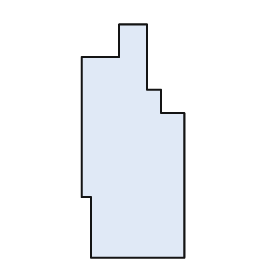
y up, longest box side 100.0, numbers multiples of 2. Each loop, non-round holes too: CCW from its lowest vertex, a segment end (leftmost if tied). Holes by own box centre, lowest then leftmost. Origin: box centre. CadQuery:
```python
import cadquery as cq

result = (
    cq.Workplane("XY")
    .moveTo(-18.0, -50.0)
    .lineTo(22.0, -50.0)
    .lineTo(22.0, 12.0)
    .lineTo(12.0, 12.0)
    .lineTo(12.0, 22.0)
    .lineTo(6.0, 22.0)
    .lineTo(6.0, 50.0)
    .lineTo(-6.0, 50.0)
    .lineTo(-6.0, 36.0)
    .lineTo(-22.0, 36.0)
    .lineTo(-22.0, -24.0)
    .lineTo(-18.0, -24.0)
    .close()
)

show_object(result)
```